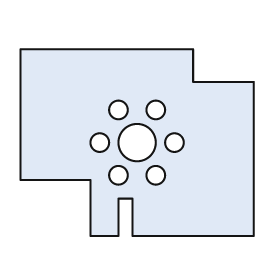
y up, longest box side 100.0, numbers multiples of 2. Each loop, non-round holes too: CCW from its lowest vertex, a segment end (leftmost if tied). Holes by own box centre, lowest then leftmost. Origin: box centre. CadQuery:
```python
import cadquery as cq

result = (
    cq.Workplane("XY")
    .moveTo(-20.0, -40.0)
    .lineTo(-8.0, -40.0)
    .lineTo(-8.0, -24.0)
    .lineTo(-2.0, -24.0)
    .lineTo(-2.0, -40.0)
    .lineTo(50.0, -40.0)
    .lineTo(50.0, 26.0)
    .lineTo(24.0, 26.0)
    .lineTo(24.0, 40.0)
    .lineTo(-50.0, 40.0)
    .lineTo(-50.0, -16.0)
    .lineTo(-20.0, -16.0)
    .close()
    .moveTo(-8.0, -14.0)
    .circle(4.0)
    .moveTo(8.0, -14.0)
    .circle(4.0)
    .moveTo(-16.0, 0.0)
    .circle(4.0)
    .moveTo(0.0, 0.0)
    .circle(8.0)
    .moveTo(16.0, 0.0)
    .circle(4.0)
    .moveTo(-8.0, 14.0)
    .circle(4.0)
    .moveTo(8.0, 14.0)
    .circle(4.0)
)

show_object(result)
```